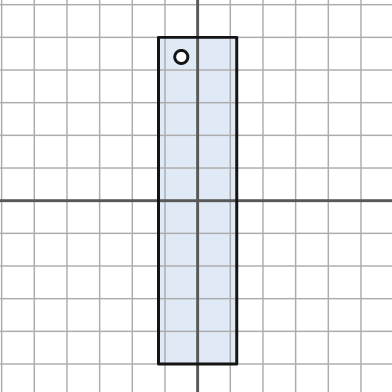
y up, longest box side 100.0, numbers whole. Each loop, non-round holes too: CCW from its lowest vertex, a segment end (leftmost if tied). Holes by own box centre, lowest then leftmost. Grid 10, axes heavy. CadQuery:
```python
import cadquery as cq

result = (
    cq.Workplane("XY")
    .moveTo(-12.0, -50.0)
    .lineTo(12.0, -50.0)
    .lineTo(12.0, 50.0)
    .lineTo(-12.0, 50.0)
    .close()
    .moveTo(-5.0, 44.0)
    .circle(2.0)
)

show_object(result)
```